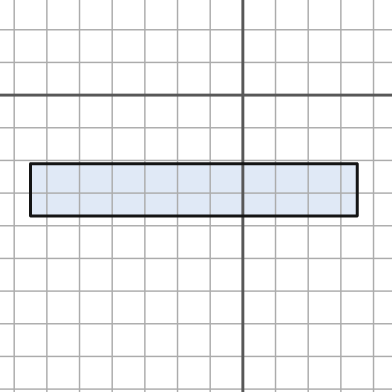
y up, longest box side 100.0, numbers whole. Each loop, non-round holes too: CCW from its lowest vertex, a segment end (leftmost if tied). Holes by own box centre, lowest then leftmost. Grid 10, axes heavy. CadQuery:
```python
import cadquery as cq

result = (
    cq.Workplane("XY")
    .moveTo(-65.0, -37.0)
    .lineTo(35.0, -37.0)
    .lineTo(35.0, -21.0)
    .lineTo(-65.0, -21.0)
    .close()
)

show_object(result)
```